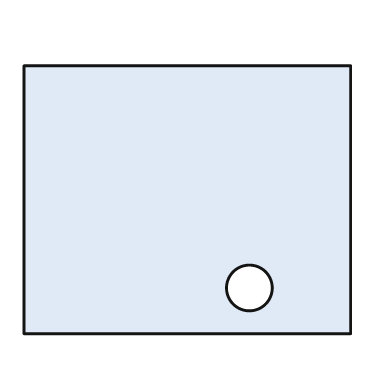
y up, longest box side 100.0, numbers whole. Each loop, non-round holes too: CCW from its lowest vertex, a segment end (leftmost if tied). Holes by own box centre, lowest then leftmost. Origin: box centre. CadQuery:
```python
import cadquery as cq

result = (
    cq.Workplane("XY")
    .moveTo(-50.0, -41.0)
    .lineTo(50.0, -41.0)
    .lineTo(50.0, 41.0)
    .lineTo(-50.0, 41.0)
    .close()
    .moveTo(19.0, -27.0)
    .circle(7.0)
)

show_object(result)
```